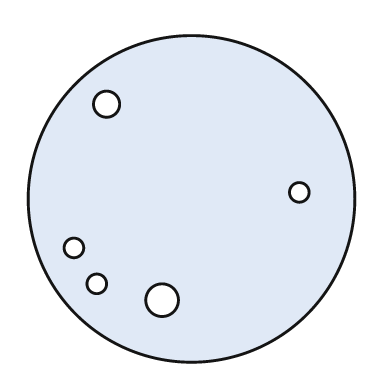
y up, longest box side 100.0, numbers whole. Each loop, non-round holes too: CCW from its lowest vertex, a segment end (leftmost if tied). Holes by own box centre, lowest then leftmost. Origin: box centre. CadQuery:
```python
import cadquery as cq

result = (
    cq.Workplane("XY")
    .moveTo(0.0, 0.0)
    .circle(50.0)
    .moveTo(-9.0, -31.0)
    .circle(5.0)
    .moveTo(-29.0, -26.0)
    .circle(3.0)
    .moveTo(-36.0, -15.0)
    .circle(3.0)
    .moveTo(33.0, 2.0)
    .circle(3.0)
    .moveTo(-26.0, 29.0)
    .circle(4.0)
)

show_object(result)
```